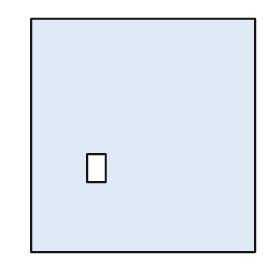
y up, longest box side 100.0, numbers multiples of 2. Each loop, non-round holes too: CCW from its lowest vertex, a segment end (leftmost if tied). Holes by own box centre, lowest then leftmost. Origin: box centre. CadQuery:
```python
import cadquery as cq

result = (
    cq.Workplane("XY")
    .moveTo(-48.0, -50.0)
    .lineTo(48.0, -50.0)
    .lineTo(48.0, 50.0)
    .lineTo(-48.0, 50.0)
    .close()
    .moveTo(-24.0, -20.0)
    .lineTo(-16.0, -20.0)
    .lineTo(-16.0, -8.0)
    .lineTo(-24.0, -8.0)
    .close()
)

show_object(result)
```